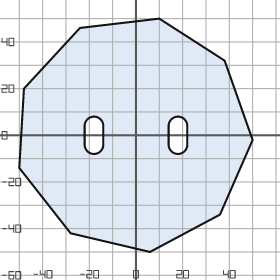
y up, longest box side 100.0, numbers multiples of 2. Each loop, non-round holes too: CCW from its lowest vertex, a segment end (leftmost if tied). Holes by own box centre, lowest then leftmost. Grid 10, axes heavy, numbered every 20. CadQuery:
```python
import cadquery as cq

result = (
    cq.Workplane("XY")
    .moveTo(6.0, -50.0)
    .lineTo(36.0, -34.0)
    .lineTo(50.0, -2.0)
    .lineTo(38.0, 32.0)
    .lineTo(10.0, 50.0)
    .lineTo(-24.0, 46.0)
    .lineTo(-48.0, 20.0)
    .lineTo(-50.0, -14.0)
    .lineTo(-28.0, -42.0)
    .close()
    .moveTo(-22.0, -4.0)
    .threePointArc((-18.0, -8.0), (-14.0, -4.0))
    .lineTo(-14.0, 4.0)
    .threePointArc((-18.0, 8.0), (-22.0, 4.0))
    .close()
    .moveTo(14.0, -4.0)
    .threePointArc((18.0, -8.0), (22.0, -4.0))
    .lineTo(22.0, 4.0)
    .threePointArc((18.0, 8.0), (14.0, 4.0))
    .close()
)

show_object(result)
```